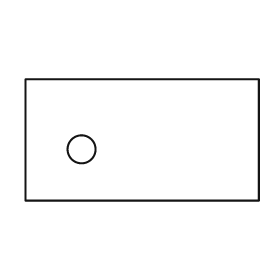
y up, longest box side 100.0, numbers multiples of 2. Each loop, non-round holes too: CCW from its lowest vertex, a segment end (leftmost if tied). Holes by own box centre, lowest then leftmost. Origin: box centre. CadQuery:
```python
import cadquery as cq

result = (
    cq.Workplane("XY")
    .moveTo(-50.0, -26.0)
    .lineTo(50.0, -26.0)
    .lineTo(50.0, 26.0)
    .lineTo(-50.0, 26.0)
    .close()
    .moveTo(-26.0, -4.0)
    .circle(6.0)
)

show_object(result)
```